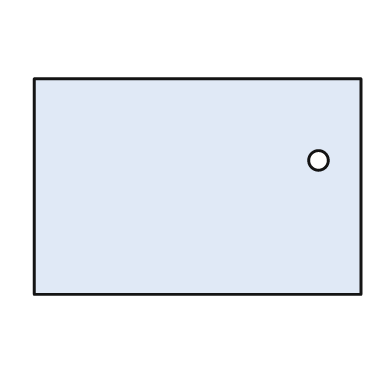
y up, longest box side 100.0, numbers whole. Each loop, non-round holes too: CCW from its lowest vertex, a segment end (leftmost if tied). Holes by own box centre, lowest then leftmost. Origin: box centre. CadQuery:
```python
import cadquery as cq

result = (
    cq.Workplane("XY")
    .moveTo(-50.0, -33.0)
    .lineTo(50.0, -33.0)
    .lineTo(50.0, 33.0)
    .lineTo(-50.0, 33.0)
    .close()
    .moveTo(37.0, 8.0)
    .circle(3.0)
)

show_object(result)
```